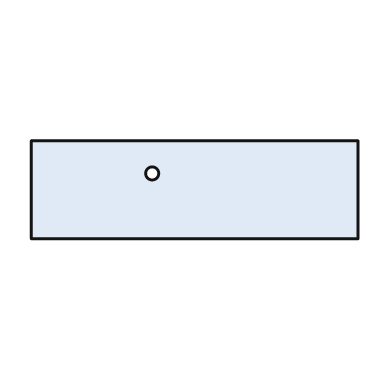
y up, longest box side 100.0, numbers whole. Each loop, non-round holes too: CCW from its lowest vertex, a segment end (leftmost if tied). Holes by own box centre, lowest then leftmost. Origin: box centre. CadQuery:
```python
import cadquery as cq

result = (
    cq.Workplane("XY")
    .moveTo(-50.0, -15.0)
    .lineTo(50.0, -15.0)
    .lineTo(50.0, 15.0)
    .lineTo(-50.0, 15.0)
    .close()
    .moveTo(-13.0, 5.0)
    .circle(2.0)
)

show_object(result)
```